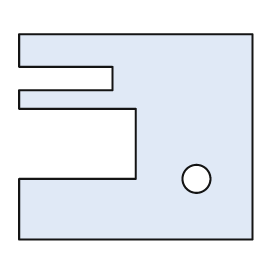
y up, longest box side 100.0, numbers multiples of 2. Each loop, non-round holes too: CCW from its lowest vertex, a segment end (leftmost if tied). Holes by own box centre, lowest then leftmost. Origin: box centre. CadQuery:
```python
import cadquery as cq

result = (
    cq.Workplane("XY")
    .moveTo(-50.0, -44.0)
    .lineTo(50.0, -44.0)
    .lineTo(50.0, 44.0)
    .lineTo(-50.0, 44.0)
    .lineTo(-50.0, 30.0)
    .lineTo(-10.0, 30.0)
    .lineTo(-10.0, 20.0)
    .lineTo(-50.0, 20.0)
    .lineTo(-50.0, 12.0)
    .lineTo(0.0, 12.0)
    .lineTo(0.0, -18.0)
    .lineTo(-50.0, -18.0)
    .close()
    .moveTo(26.0, -18.0)
    .circle(6.0)
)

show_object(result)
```